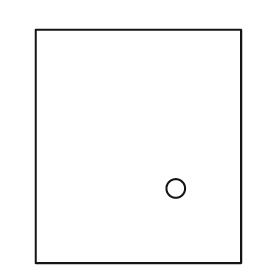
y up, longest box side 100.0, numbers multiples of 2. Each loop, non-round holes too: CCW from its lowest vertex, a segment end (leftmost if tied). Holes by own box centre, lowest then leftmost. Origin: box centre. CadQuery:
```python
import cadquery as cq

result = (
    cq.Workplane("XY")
    .moveTo(-44.0, -50.0)
    .lineTo(44.0, -50.0)
    .lineTo(44.0, 50.0)
    .lineTo(-44.0, 50.0)
    .close()
    .moveTo(16.0, -18.0)
    .circle(4.0)
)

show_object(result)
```